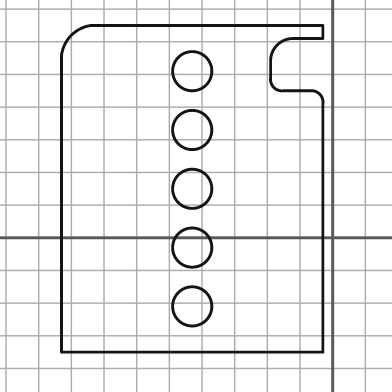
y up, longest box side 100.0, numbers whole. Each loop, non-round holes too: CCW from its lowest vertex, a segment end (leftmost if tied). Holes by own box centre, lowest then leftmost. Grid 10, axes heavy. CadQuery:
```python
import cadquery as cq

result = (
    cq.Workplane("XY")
    .moveTo(-83.0, -35.0)
    .lineTo(-3.0, -35.0)
    .lineTo(-3.0, 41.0)
    .threePointArc((-4.0, 44.0), (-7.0, 45.0))
    .lineTo(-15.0, 45.0)
    .threePointArc((-18.0, 46.0), (-19.0, 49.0))
    .lineTo(-19.0, 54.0)
    .threePointArc((-17.0, 59.0), (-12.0, 61.0))
    .lineTo(-3.0, 61.0)
    .lineTo(-3.0, 65.0)
    .lineTo(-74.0, 65.0)
    .threePointArc((-80.0, 62.0), (-83.0, 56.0))
    .close()
    .moveTo(-43.0, -21.0)
    .circle(6.0)
    .moveTo(-43.0, -3.0)
    .circle(6.0)
    .moveTo(-43.0, 15.0)
    .circle(6.0)
    .moveTo(-43.0, 33.0)
    .circle(6.0)
    .moveTo(-43.0, 51.0)
    .circle(6.0)
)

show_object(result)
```